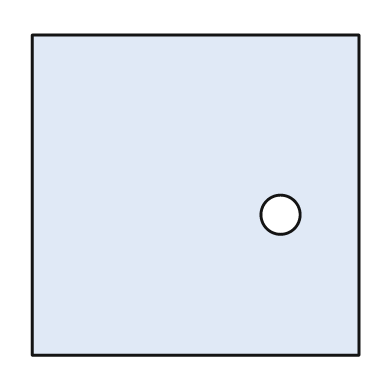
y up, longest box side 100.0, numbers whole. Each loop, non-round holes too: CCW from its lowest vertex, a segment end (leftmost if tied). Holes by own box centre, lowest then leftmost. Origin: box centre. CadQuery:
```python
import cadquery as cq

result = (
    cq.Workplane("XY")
    .moveTo(-50.0, -49.0)
    .lineTo(50.0, -49.0)
    .lineTo(50.0, 49.0)
    .lineTo(-50.0, 49.0)
    .close()
    .moveTo(26.0, -6.0)
    .circle(6.0)
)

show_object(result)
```